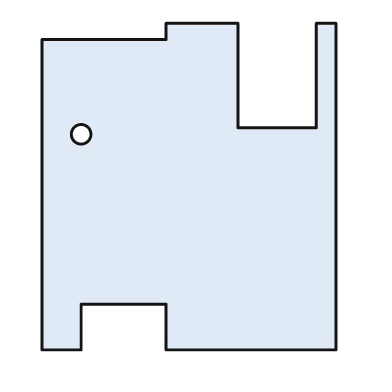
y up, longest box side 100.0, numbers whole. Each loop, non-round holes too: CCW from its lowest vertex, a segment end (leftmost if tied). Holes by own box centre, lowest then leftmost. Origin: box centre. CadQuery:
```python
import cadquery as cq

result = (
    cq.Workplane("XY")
    .moveTo(-45.0, -50.0)
    .lineTo(-33.0, -50.0)
    .lineTo(-33.0, -36.0)
    .lineTo(-7.0, -36.0)
    .lineTo(-7.0, -50.0)
    .lineTo(45.0, -50.0)
    .lineTo(45.0, 50.0)
    .lineTo(39.0, 50.0)
    .lineTo(39.0, 18.0)
    .lineTo(15.0, 18.0)
    .lineTo(15.0, 50.0)
    .lineTo(-7.0, 50.0)
    .lineTo(-7.0, 45.0)
    .lineTo(-45.0, 45.0)
    .close()
    .moveTo(-33.0, 16.0)
    .circle(3.0)
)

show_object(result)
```